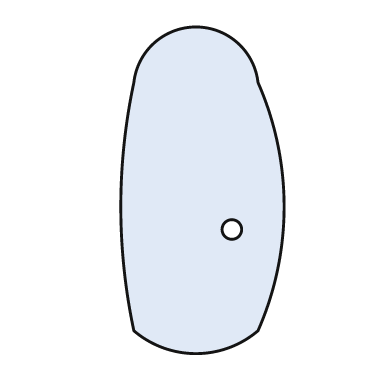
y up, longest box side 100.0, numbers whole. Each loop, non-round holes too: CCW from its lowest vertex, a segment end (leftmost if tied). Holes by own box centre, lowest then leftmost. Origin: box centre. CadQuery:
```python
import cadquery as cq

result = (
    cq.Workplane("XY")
    .moveTo(-21.0, -43.0)
    .threePointArc((-2.0, -50.0), (17.0, -43.0))
    .threePointArc((25.0, -5.0), (17.0, 33.0))
    .threePointArc((-2.0, 50.0), (-21.0, 33.0))
    .threePointArc((-25.0, -5.0), (-21.0, -43.0))
    .close()
    .moveTo(9.0, -12.0)
    .circle(3.0)
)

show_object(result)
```